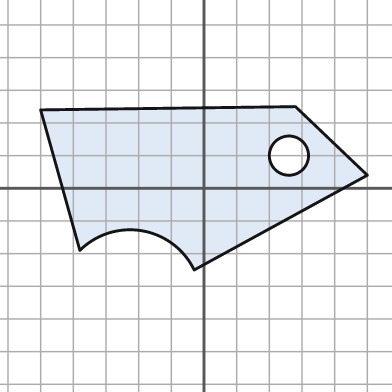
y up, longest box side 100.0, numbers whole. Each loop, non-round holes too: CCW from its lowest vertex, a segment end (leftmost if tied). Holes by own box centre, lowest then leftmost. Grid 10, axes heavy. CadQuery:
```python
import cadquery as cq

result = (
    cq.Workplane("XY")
    .moveTo(-3.0, -25.0)
    .lineTo(50.0, 4.0)
    .lineTo(28.0, 25.0)
    .lineTo(-50.0, 24.0)
    .lineTo(-38.0, -19.0)
    .threePointArc((-19.0, -13.0), (-3.0, -25.0))
    .close()
    .moveTo(26.0, 10.0)
    .circle(6.0)
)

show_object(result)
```